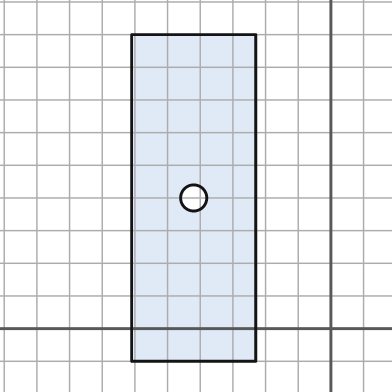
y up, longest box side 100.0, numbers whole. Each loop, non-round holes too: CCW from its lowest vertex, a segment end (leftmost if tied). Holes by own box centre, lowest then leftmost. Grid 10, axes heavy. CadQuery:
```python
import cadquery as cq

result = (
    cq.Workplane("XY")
    .moveTo(-61.0, -10.0)
    .lineTo(-23.0, -10.0)
    .lineTo(-23.0, 90.0)
    .lineTo(-61.0, 90.0)
    .close()
    .moveTo(-42.0, 40.0)
    .circle(4.0)
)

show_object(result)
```